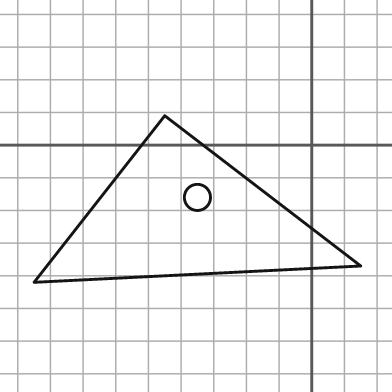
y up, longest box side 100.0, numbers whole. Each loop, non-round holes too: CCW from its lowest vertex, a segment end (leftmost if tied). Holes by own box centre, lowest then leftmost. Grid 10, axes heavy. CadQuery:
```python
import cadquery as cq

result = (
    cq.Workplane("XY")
    .moveTo(-85.0, -42.0)
    .lineTo(15.0, -37.0)
    .lineTo(-45.0, 9.0)
    .close()
    .moveTo(-35.0, -16.0)
    .circle(4.0)
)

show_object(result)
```